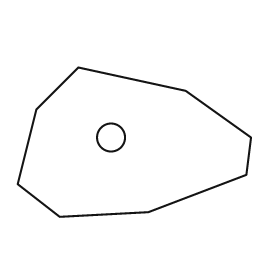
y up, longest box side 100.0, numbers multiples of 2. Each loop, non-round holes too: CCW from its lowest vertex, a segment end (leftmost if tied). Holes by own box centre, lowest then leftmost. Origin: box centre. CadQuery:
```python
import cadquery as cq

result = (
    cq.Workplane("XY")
    .moveTo(-32.0, -32.0)
    .lineTo(6.0, -30.0)
    .lineTo(48.0, -14.0)
    .lineTo(50.0, 2.0)
    .lineTo(22.0, 22.0)
    .lineTo(-24.0, 32.0)
    .lineTo(-42.0, 14.0)
    .lineTo(-50.0, -18.0)
    .close()
    .moveTo(-10.0, 2.0)
    .circle(6.0)
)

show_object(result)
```